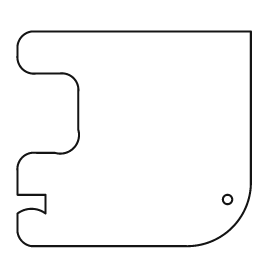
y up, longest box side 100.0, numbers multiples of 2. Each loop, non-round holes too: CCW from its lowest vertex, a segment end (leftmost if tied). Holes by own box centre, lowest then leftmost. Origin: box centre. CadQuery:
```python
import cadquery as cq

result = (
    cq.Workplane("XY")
    .moveTo(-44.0, -46.0)
    .lineTo(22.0, -46.0)
    .threePointArc((42.0, -38.0), (50.0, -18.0))
    .lineTo(50.0, 46.0)
    .lineTo(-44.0, 46.0)
    .threePointArc((-48.0, 44.0), (-50.0, 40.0))
    .lineTo(-50.0, 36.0)
    .threePointArc((-48.0, 30.0), (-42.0, 28.0))
    .lineTo(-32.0, 28.0)
    .threePointArc((-26.0, 26.0), (-24.0, 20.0))
    .lineTo(-24.0, 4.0)
    .threePointArc((-26.0, -4.0), (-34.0, -6.0))
    .lineTo(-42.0, -6.0)
    .threePointArc((-48.0, -8.0), (-50.0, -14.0))
    .lineTo(-50.0, -24.0)
    .lineTo(-38.0, -24.0)
    .lineTo(-38.0, -32.0)
    .threePointArc((-44.0, -30.0), (-50.0, -32.0))
    .lineTo(-50.0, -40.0)
    .threePointArc((-48.0, -44.0), (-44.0, -46.0))
    .close()
    .moveTo(40.0, -26.0)
    .circle(2.0)
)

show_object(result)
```